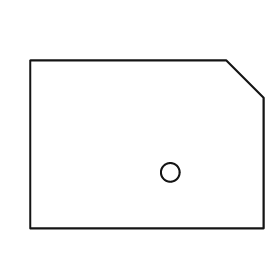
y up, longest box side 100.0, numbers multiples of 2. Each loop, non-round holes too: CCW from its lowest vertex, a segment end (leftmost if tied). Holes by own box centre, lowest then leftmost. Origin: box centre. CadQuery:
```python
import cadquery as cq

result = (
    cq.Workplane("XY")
    .moveTo(-50.0, -36.0)
    .lineTo(50.0, -36.0)
    .lineTo(50.0, 20.0)
    .lineTo(34.0, 36.0)
    .lineTo(-50.0, 36.0)
    .close()
    .moveTo(10.0, -12.0)
    .circle(4.0)
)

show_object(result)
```